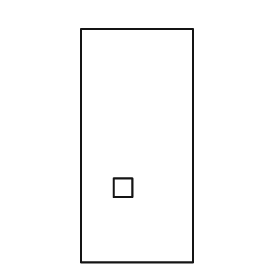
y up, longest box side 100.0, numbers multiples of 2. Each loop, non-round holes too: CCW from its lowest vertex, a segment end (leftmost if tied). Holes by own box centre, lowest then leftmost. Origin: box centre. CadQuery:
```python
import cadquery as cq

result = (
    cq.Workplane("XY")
    .moveTo(-24.0, -50.0)
    .lineTo(24.0, -50.0)
    .lineTo(24.0, 50.0)
    .lineTo(-24.0, 50.0)
    .close()
    .moveTo(-10.0, -22.0)
    .lineTo(-2.0, -22.0)
    .lineTo(-2.0, -14.0)
    .lineTo(-10.0, -14.0)
    .close()
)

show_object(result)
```